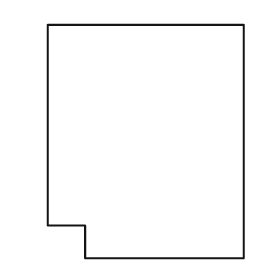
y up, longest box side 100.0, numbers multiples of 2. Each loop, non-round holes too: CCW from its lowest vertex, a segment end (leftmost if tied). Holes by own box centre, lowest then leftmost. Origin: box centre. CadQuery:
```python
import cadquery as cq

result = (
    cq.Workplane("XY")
    .moveTo(-26.0, -50.0)
    .lineTo(42.0, -50.0)
    .lineTo(42.0, 50.0)
    .lineTo(-42.0, 50.0)
    .lineTo(-42.0, -36.0)
    .lineTo(-26.0, -36.0)
    .close()
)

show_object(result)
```